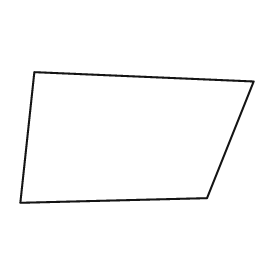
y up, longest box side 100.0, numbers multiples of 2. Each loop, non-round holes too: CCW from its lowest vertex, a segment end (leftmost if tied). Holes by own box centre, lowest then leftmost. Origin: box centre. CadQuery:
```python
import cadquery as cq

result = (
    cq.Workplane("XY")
    .moveTo(-50.0, -28.0)
    .lineTo(30.0, -26.0)
    .lineTo(50.0, 24.0)
    .lineTo(-44.0, 28.0)
    .close()
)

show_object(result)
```